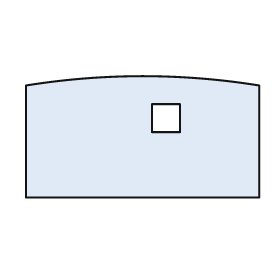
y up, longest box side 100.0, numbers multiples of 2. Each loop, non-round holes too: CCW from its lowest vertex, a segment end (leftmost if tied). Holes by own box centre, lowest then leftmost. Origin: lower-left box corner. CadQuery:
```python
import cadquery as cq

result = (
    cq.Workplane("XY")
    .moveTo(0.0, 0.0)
    .lineTo(100.0, 0.0)
    .lineTo(100.0, 48.0)
    .threePointArc((50.0, 52.0), (0.0, 48.0))
    .close()
    .moveTo(54.0, 28.0)
    .lineTo(66.0, 28.0)
    .lineTo(66.0, 40.0)
    .lineTo(54.0, 40.0)
    .close()
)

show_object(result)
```